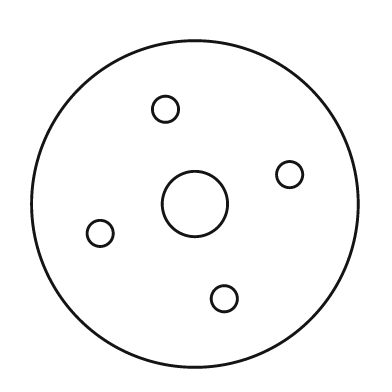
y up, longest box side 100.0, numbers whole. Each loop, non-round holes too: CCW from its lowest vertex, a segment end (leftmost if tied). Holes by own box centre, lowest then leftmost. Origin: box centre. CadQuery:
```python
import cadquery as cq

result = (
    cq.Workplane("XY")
    .moveTo(0.0, 0.0)
    .circle(50.0)
    .moveTo(9.0, -29.0)
    .circle(4.0)
    .moveTo(-29.0, -9.0)
    .circle(4.0)
    .moveTo(0.0, 0.0)
    .circle(10.0)
    .moveTo(29.0, 9.0)
    .circle(4.0)
    .moveTo(-9.0, 29.0)
    .circle(4.0)
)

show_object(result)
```